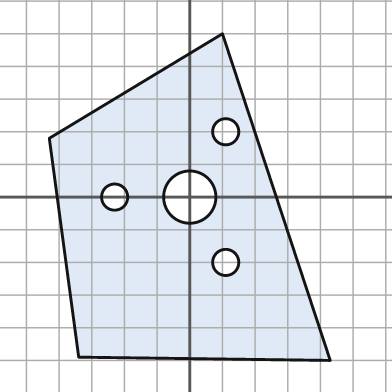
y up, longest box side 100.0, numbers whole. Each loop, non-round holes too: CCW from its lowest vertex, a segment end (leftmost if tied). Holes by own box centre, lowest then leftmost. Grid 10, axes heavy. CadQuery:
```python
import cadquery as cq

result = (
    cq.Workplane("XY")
    .moveTo(43.0, -50.0)
    .lineTo(10.0, 50.0)
    .lineTo(-43.0, 18.0)
    .lineTo(-34.0, -49.0)
    .close()
    .moveTo(11.0, -20.0)
    .circle(4.0)
    .moveTo(-23.0, 0.0)
    .circle(4.0)
    .moveTo(0.0, 0.0)
    .circle(8.0)
    .moveTo(11.0, 20.0)
    .circle(4.0)
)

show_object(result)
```